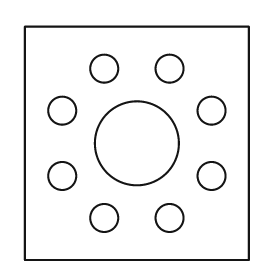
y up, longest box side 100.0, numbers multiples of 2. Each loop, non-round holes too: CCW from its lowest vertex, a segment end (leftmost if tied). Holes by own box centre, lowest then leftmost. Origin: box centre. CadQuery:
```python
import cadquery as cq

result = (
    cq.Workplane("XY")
    .moveTo(-48.0, -50.0)
    .lineTo(48.0, -50.0)
    .lineTo(48.0, 50.0)
    .lineTo(-48.0, 50.0)
    .close()
    .moveTo(-14.0, -32.0)
    .circle(6.0)
    .moveTo(14.0, -32.0)
    .circle(6.0)
    .moveTo(-32.0, -14.0)
    .circle(6.0)
    .moveTo(32.0, -14.0)
    .circle(6.0)
    .moveTo(0.0, 0.0)
    .circle(18.0)
    .moveTo(-32.0, 14.0)
    .circle(6.0)
    .moveTo(32.0, 14.0)
    .circle(6.0)
    .moveTo(-14.0, 32.0)
    .circle(6.0)
    .moveTo(14.0, 32.0)
    .circle(6.0)
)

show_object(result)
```